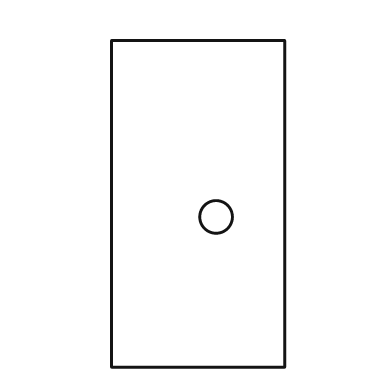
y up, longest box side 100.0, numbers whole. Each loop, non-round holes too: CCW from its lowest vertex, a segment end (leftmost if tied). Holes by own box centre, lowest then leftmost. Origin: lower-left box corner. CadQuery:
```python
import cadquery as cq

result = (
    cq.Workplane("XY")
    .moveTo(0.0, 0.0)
    .lineTo(53.0, 0.0)
    .lineTo(53.0, 100.0)
    .lineTo(0.0, 100.0)
    .close()
    .moveTo(32.0, 46.0)
    .circle(5.0)
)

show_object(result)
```